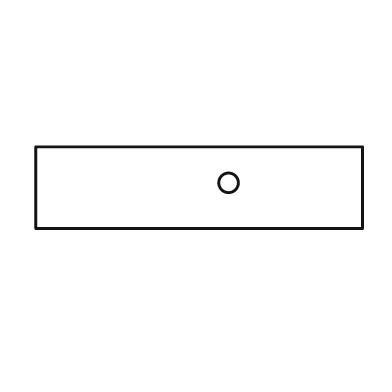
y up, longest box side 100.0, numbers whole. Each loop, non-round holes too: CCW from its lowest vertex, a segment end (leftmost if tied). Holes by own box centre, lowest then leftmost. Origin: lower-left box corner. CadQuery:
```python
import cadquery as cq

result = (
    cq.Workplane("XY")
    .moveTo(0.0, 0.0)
    .lineTo(100.0, 0.0)
    .lineTo(100.0, 25.0)
    .lineTo(0.0, 25.0)
    .close()
    .moveTo(59.0, 14.0)
    .circle(3.0)
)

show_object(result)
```